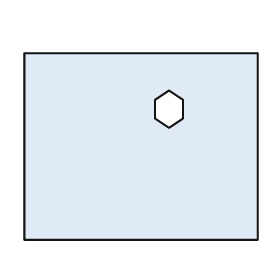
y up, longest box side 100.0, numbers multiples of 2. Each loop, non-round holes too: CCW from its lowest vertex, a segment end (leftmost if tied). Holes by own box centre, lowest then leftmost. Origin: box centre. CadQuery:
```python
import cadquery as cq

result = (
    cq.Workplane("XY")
    .moveTo(-50.0, -40.0)
    .lineTo(50.0, -40.0)
    .lineTo(50.0, 40.0)
    .lineTo(-50.0, 40.0)
    .close()
    .moveTo(12.0, 8.0)
    .lineTo(18.0, 12.0)
    .lineTo(18.0, 20.0)
    .lineTo(12.0, 24.0)
    .lineTo(6.0, 20.0)
    .lineTo(6.0, 12.0)
    .close()
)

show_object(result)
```